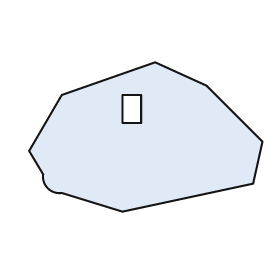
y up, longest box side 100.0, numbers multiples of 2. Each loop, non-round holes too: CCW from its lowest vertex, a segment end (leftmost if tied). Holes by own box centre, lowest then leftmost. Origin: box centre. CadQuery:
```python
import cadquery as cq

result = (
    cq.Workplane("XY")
    .moveTo(-10.0, -32.0)
    .lineTo(46.0, -20.0)
    .lineTo(50.0, -2.0)
    .lineTo(26.0, 22.0)
    .lineTo(4.0, 32.0)
    .lineTo(-36.0, 18.0)
    .lineTo(-50.0, -6.0)
    .lineTo(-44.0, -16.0)
    .threePointArc((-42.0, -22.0), (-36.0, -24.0))
    .close()
    .moveTo(-10.0, 6.0)
    .lineTo(-2.0, 6.0)
    .lineTo(-2.0, 18.0)
    .lineTo(-10.0, 18.0)
    .close()
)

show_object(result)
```